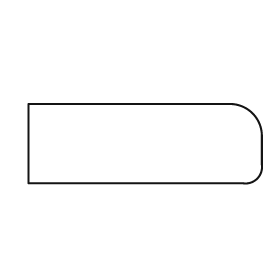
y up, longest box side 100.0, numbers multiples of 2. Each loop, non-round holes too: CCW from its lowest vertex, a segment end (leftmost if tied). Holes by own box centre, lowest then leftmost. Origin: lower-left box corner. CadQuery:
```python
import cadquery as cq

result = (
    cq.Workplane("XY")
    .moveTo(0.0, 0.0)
    .lineTo(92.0, 0.0)
    .threePointArc((98.0, 2.0), (100.0, 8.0))
    .lineTo(100.0, 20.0)
    .threePointArc((96.0, 30.0), (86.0, 34.0))
    .lineTo(0.0, 34.0)
    .close()
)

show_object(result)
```